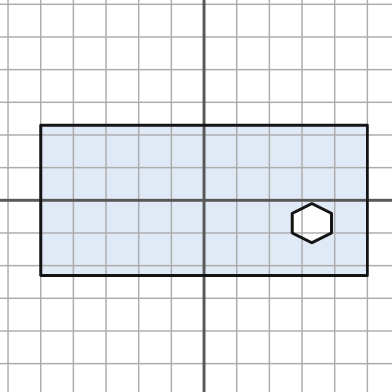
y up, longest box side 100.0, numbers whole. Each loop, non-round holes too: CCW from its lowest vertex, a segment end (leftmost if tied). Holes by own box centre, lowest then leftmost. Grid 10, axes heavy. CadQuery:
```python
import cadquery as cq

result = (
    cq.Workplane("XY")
    .moveTo(-50.0, -23.0)
    .lineTo(50.0, -23.0)
    .lineTo(50.0, 23.0)
    .lineTo(-50.0, 23.0)
    .close()
    .moveTo(33.0, -13.0)
    .lineTo(39.0, -10.0)
    .lineTo(39.0, -4.0)
    .lineTo(33.0, -1.0)
    .lineTo(27.0, -4.0)
    .lineTo(27.0, -10.0)
    .close()
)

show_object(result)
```